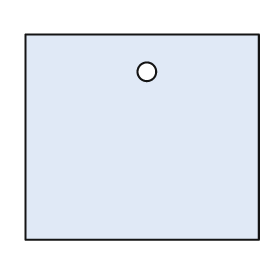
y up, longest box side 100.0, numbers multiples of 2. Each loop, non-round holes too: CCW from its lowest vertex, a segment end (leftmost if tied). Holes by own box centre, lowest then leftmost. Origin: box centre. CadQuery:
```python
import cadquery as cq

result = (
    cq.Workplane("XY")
    .moveTo(-50.0, -44.0)
    .lineTo(50.0, -44.0)
    .lineTo(50.0, 44.0)
    .lineTo(-50.0, 44.0)
    .close()
    .moveTo(2.0, 28.0)
    .circle(4.0)
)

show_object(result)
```